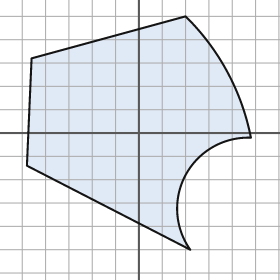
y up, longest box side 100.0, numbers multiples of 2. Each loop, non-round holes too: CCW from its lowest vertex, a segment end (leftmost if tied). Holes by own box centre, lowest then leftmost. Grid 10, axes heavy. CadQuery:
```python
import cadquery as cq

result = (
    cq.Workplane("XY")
    .moveTo(22.0, -50.0)
    .threePointArc((20.0, -18.0), (48.0, -2.0))
    .threePointArc((38.0, 26.0), (20.0, 50.0))
    .lineTo(-46.0, 32.0)
    .lineTo(-48.0, -14.0)
    .close()
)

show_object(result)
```